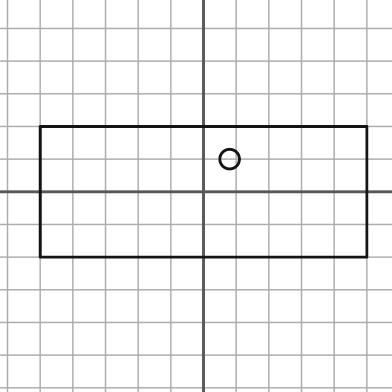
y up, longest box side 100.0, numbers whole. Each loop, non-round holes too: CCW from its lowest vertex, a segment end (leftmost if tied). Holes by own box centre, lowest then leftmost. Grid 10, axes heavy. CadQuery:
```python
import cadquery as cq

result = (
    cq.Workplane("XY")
    .moveTo(-50.0, -20.0)
    .lineTo(50.0, -20.0)
    .lineTo(50.0, 20.0)
    .lineTo(-50.0, 20.0)
    .close()
    .moveTo(8.0, 10.0)
    .circle(3.0)
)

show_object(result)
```